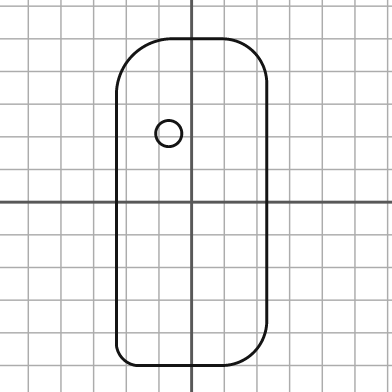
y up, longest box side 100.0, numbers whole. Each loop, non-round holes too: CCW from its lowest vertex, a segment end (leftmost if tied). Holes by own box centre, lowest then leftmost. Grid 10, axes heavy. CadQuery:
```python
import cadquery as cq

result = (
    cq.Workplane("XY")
    .moveTo(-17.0, -50.0)
    .lineTo(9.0, -50.0)
    .threePointArc((19.0, -46.0), (23.0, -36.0))
    .lineTo(23.0, 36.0)
    .threePointArc((19.0, 46.0), (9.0, 50.0))
    .lineTo(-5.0, 50.0)
    .threePointArc((-18.0, 45.0), (-23.0, 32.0))
    .lineTo(-23.0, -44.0)
    .threePointArc((-21.0, -48.0), (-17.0, -50.0))
    .close()
    .moveTo(-7.0, 21.0)
    .circle(4.0)
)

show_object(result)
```